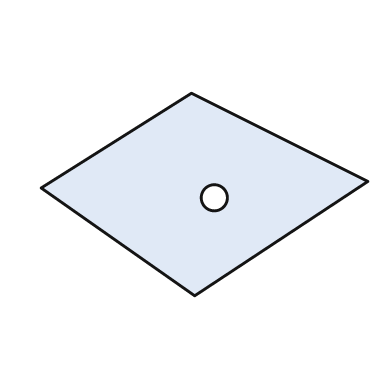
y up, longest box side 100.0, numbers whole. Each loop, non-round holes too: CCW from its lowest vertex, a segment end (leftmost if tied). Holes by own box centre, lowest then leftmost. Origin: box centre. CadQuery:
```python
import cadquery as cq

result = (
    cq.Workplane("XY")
    .moveTo(-3.0, -31.0)
    .lineTo(50.0, 4.0)
    .lineTo(-4.0, 31.0)
    .lineTo(-50.0, 2.0)
    .close()
    .moveTo(3.0, -1.0)
    .circle(4.0)
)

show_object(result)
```